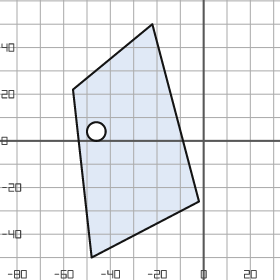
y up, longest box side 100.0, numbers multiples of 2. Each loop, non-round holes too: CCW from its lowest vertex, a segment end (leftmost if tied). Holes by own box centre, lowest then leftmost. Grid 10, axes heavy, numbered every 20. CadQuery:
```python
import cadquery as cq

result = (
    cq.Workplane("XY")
    .moveTo(-48.0, -50.0)
    .lineTo(-2.0, -26.0)
    .lineTo(-22.0, 50.0)
    .lineTo(-56.0, 22.0)
    .close()
    .moveTo(-46.0, 4.0)
    .circle(4.0)
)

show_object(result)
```